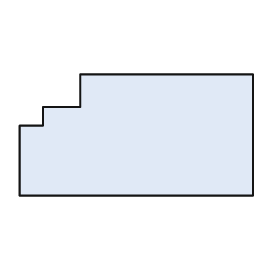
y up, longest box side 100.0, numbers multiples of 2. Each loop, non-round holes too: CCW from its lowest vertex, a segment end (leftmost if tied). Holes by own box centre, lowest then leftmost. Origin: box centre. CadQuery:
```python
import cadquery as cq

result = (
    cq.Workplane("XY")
    .moveTo(-50.0, -26.0)
    .lineTo(50.0, -26.0)
    .lineTo(50.0, 26.0)
    .lineTo(-24.0, 26.0)
    .lineTo(-24.0, 12.0)
    .lineTo(-40.0, 12.0)
    .lineTo(-40.0, 4.0)
    .lineTo(-50.0, 4.0)
    .close()
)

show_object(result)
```